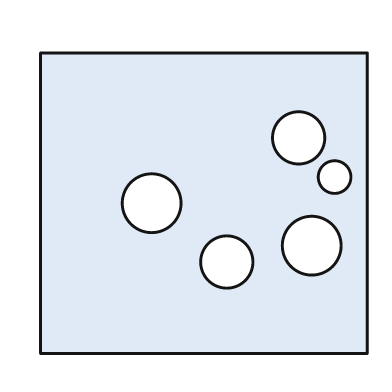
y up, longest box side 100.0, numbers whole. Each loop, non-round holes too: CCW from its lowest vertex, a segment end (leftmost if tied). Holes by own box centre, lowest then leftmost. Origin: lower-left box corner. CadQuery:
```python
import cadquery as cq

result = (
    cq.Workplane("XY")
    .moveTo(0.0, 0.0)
    .lineTo(100.0, 0.0)
    .lineTo(100.0, 92.0)
    .lineTo(0.0, 92.0)
    .close()
    .moveTo(57.0, 28.0)
    .circle(8.0)
    .moveTo(83.0, 33.0)
    .circle(9.0)
    .moveTo(34.0, 46.0)
    .circle(9.0)
    .moveTo(90.0, 54.0)
    .circle(5.0)
    .moveTo(79.0, 66.0)
    .circle(8.0)
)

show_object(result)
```